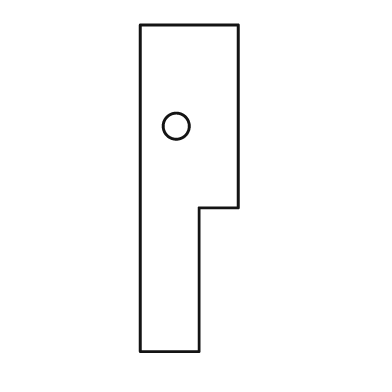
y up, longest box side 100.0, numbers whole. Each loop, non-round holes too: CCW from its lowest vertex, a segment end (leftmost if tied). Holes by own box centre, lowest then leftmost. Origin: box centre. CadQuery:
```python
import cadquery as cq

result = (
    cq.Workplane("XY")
    .moveTo(-15.0, -50.0)
    .lineTo(3.0, -50.0)
    .lineTo(3.0, -6.0)
    .lineTo(15.0, -6.0)
    .lineTo(15.0, 50.0)
    .lineTo(-15.0, 50.0)
    .close()
    .moveTo(-4.0, 19.0)
    .circle(4.0)
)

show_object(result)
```